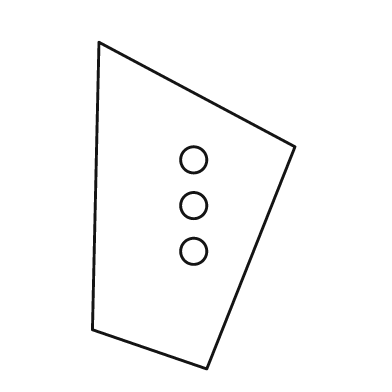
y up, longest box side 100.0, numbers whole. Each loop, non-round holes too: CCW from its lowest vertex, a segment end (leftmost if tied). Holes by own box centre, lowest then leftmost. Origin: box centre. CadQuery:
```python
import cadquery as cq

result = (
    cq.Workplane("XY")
    .moveTo(4.0, -50.0)
    .lineTo(31.0, 18.0)
    .lineTo(-29.0, 50.0)
    .lineTo(-31.0, -38.0)
    .close()
    .moveTo(0.0, -14.0)
    .circle(4.0)
    .moveTo(0.0, 0.0)
    .circle(4.0)
    .moveTo(0.0, 14.0)
    .circle(4.0)
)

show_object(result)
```